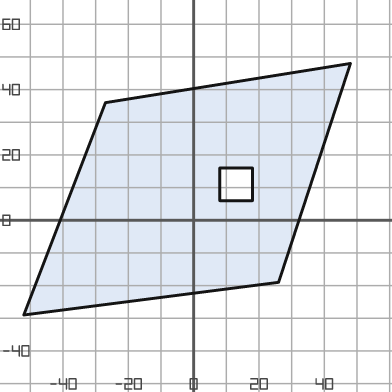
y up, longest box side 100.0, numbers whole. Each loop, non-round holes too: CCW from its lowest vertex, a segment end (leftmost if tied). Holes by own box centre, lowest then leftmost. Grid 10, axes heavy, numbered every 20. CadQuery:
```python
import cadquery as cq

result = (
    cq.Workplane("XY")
    .moveTo(-52.0, -29.0)
    .lineTo(26.0, -19.0)
    .lineTo(48.0, 48.0)
    .lineTo(-27.0, 36.0)
    .close()
    .moveTo(8.0, 6.0)
    .lineTo(18.0, 6.0)
    .lineTo(18.0, 16.0)
    .lineTo(8.0, 16.0)
    .close()
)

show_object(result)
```